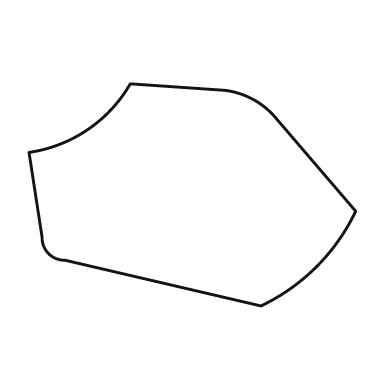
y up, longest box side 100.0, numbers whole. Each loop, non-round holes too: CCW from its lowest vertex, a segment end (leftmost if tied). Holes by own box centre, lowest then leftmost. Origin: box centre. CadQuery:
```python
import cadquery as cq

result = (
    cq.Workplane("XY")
    .moveTo(21.0, -34.0)
    .threePointArc((38.0, -22.0), (50.0, -5.0))
    .lineTo(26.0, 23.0)
    .threePointArc((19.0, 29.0), (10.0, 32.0))
    .lineTo(-19.0, 34.0)
    .threePointArc((-32.0, 20.0), (-50.0, 13.0))
    .lineTo(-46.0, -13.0)
    .threePointArc((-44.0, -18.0), (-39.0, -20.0))
    .close()
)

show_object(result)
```